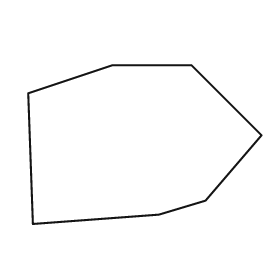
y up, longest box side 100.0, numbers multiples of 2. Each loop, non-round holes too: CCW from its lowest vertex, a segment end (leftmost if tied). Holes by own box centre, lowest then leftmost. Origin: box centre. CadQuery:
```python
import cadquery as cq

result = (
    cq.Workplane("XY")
    .moveTo(-48.0, -34.0)
    .lineTo(6.0, -30.0)
    .lineTo(26.0, -24.0)
    .lineTo(50.0, 4.0)
    .lineTo(20.0, 34.0)
    .lineTo(-14.0, 34.0)
    .lineTo(-50.0, 22.0)
    .close()
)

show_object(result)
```